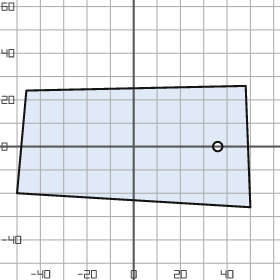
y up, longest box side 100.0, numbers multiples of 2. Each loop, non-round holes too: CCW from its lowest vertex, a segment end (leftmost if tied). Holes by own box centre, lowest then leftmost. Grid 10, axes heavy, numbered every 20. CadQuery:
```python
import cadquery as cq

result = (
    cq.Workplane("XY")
    .moveTo(50.0, -26.0)
    .lineTo(48.0, 26.0)
    .lineTo(-46.0, 24.0)
    .lineTo(-50.0, -20.0)
    .close()
    .moveTo(36.0, 0.0)
    .circle(2.0)
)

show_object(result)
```